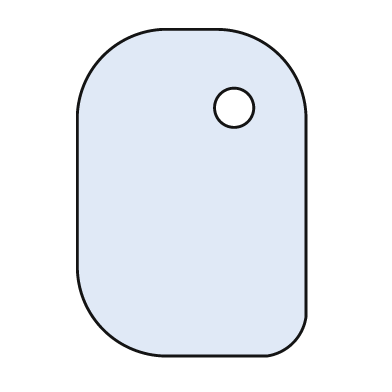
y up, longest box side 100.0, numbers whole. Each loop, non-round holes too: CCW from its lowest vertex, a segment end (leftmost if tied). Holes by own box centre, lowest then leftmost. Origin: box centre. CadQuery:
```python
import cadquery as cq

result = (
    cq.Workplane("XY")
    .moveTo(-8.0, -50.0)
    .lineTo(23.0, -50.0)
    .threePointArc((31.0, -46.0), (35.0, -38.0))
    .lineTo(35.0, 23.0)
    .threePointArc((27.0, 42.0), (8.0, 50.0))
    .lineTo(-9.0, 50.0)
    .threePointArc((-27.0, 42.0), (-35.0, 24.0))
    .lineTo(-35.0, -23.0)
    .threePointArc((-27.0, -42.0), (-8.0, -50.0))
    .close()
    .moveTo(13.0, 26.0)
    .circle(6.0)
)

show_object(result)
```